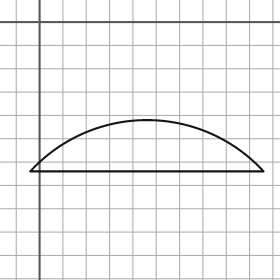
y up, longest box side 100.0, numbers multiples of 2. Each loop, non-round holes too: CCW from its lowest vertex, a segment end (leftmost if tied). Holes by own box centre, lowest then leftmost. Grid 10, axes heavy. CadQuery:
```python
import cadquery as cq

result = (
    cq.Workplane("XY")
    .moveTo(-4.0, -64.0)
    .lineTo(96.0, -64.0)
    .threePointArc((46.0, -42.0), (-4.0, -64.0))
    .close()
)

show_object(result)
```